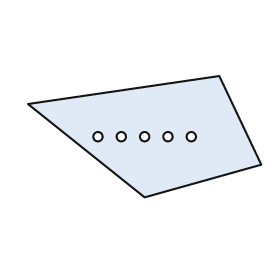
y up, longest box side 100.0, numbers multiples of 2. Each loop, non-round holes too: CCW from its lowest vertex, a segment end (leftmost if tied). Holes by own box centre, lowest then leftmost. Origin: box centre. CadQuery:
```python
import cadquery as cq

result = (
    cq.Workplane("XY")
    .moveTo(0.0, -26.0)
    .lineTo(50.0, -12.0)
    .lineTo(32.0, 26.0)
    .lineTo(-50.0, 14.0)
    .close()
    .moveTo(-20.0, 0.0)
    .circle(2.0)
    .moveTo(-10.0, 0.0)
    .circle(2.0)
    .moveTo(0.0, 0.0)
    .circle(2.0)
    .moveTo(10.0, 0.0)
    .circle(2.0)
    .moveTo(20.0, 0.0)
    .circle(2.0)
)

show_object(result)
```